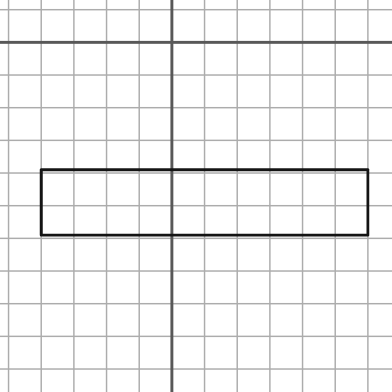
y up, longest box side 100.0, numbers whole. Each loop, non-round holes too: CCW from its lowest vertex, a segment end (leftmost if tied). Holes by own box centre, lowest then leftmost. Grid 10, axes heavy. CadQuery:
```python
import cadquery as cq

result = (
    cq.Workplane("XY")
    .moveTo(-40.0, -59.0)
    .lineTo(60.0, -59.0)
    .lineTo(60.0, -39.0)
    .lineTo(-40.0, -39.0)
    .close()
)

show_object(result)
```